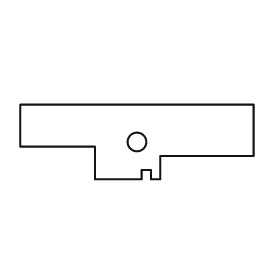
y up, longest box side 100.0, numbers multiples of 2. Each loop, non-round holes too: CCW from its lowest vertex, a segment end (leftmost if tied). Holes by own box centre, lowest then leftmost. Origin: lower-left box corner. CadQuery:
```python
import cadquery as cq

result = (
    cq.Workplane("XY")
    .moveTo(32.0, 0.0)
    .lineTo(52.0, 0.0)
    .lineTo(52.0, 4.0)
    .lineTo(56.0, 4.0)
    .lineTo(56.0, 0.0)
    .lineTo(60.0, 0.0)
    .lineTo(60.0, 10.0)
    .lineTo(100.0, 10.0)
    .lineTo(100.0, 32.0)
    .lineTo(0.0, 32.0)
    .lineTo(0.0, 14.0)
    .lineTo(32.0, 14.0)
    .close()
    .moveTo(50.0, 16.0)
    .circle(4.0)
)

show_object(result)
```